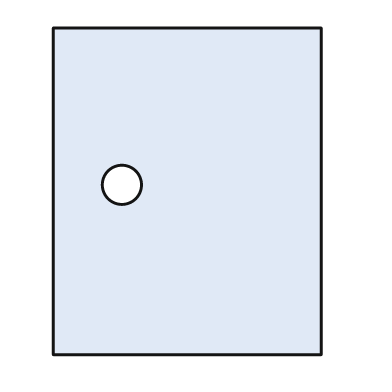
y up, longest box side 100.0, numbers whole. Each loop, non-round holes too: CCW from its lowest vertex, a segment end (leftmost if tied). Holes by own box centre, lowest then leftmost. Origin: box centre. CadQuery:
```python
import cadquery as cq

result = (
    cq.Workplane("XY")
    .moveTo(-41.0, -50.0)
    .lineTo(41.0, -50.0)
    .lineTo(41.0, 50.0)
    .lineTo(-41.0, 50.0)
    .close()
    .moveTo(-20.0, 2.0)
    .circle(6.0)
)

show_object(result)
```